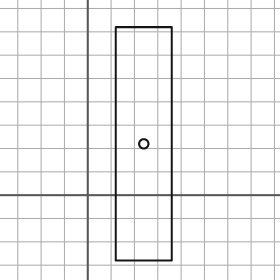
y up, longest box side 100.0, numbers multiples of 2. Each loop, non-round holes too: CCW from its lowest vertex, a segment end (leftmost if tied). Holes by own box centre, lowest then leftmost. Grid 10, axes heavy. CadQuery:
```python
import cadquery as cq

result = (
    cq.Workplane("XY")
    .moveTo(12.0, -28.0)
    .lineTo(36.0, -28.0)
    .lineTo(36.0, 72.0)
    .lineTo(12.0, 72.0)
    .close()
    .moveTo(24.0, 22.0)
    .circle(2.0)
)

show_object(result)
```